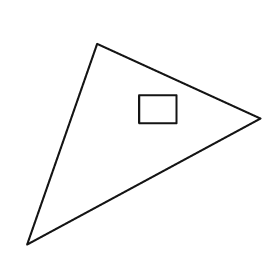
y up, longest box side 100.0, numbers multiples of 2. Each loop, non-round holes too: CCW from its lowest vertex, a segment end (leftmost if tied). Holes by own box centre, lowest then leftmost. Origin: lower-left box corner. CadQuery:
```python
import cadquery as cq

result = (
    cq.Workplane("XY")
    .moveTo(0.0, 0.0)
    .lineTo(100.0, 54.0)
    .lineTo(30.0, 86.0)
    .close()
    .moveTo(48.0, 52.0)
    .lineTo(64.0, 52.0)
    .lineTo(64.0, 64.0)
    .lineTo(48.0, 64.0)
    .close()
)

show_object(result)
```